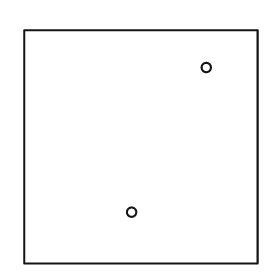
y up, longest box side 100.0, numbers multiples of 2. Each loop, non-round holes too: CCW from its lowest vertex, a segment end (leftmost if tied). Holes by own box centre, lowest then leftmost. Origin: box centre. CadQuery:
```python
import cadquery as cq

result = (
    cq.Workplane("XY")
    .moveTo(-50.0, -50.0)
    .lineTo(50.0, -50.0)
    .lineTo(50.0, 50.0)
    .lineTo(-50.0, 50.0)
    .close()
    .moveTo(-4.0, -28.0)
    .circle(2.0)
    .moveTo(28.0, 34.0)
    .circle(2.0)
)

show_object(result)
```